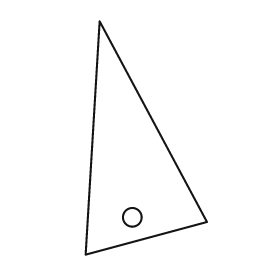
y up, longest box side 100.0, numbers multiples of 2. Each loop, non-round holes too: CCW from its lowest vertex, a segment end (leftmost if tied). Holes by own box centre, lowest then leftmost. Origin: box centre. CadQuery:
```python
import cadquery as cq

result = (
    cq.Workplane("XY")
    .moveTo(-26.0, -50.0)
    .lineTo(26.0, -36.0)
    .lineTo(-20.0, 50.0)
    .close()
    .moveTo(-6.0, -34.0)
    .circle(4.0)
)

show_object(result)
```